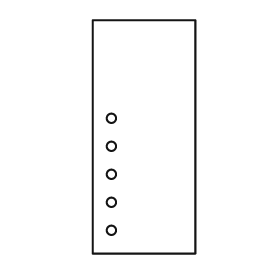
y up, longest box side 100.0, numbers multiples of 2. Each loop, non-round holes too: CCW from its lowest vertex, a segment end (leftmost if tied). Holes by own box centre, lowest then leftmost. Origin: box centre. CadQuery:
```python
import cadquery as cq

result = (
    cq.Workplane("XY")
    .moveTo(-22.0, -50.0)
    .lineTo(22.0, -50.0)
    .lineTo(22.0, 50.0)
    .lineTo(-22.0, 50.0)
    .close()
    .moveTo(-14.0, -40.0)
    .circle(2.0)
    .moveTo(-14.0, -28.0)
    .circle(2.0)
    .moveTo(-14.0, -16.0)
    .circle(2.0)
    .moveTo(-14.0, -4.0)
    .circle(2.0)
    .moveTo(-14.0, 8.0)
    .circle(2.0)
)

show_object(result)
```